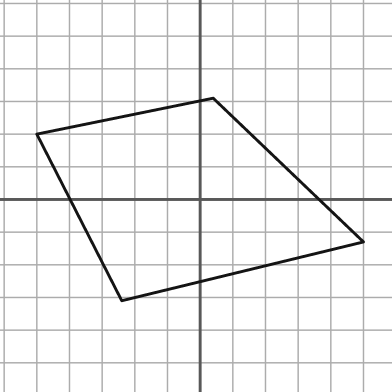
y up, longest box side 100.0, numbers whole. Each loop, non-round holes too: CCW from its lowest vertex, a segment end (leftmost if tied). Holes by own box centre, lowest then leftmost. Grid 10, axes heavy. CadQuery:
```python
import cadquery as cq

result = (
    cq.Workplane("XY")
    .moveTo(-24.0, -31.0)
    .lineTo(50.0, -13.0)
    .lineTo(4.0, 31.0)
    .lineTo(-50.0, 20.0)
    .close()
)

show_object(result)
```